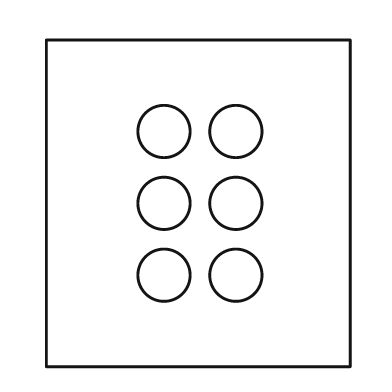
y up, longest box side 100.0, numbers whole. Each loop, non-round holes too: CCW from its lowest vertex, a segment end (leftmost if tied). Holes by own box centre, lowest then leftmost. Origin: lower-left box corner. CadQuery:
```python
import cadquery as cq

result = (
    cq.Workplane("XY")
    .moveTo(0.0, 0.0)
    .lineTo(93.0, 0.0)
    .lineTo(93.0, 100.0)
    .lineTo(0.0, 100.0)
    .close()
    .moveTo(36.0, 28.0)
    .circle(8.0)
    .moveTo(58.0, 28.0)
    .circle(8.0)
    .moveTo(36.0, 50.0)
    .circle(8.0)
    .moveTo(58.0, 50.0)
    .circle(8.0)
    .moveTo(36.0, 72.0)
    .circle(8.0)
    .moveTo(58.0, 72.0)
    .circle(8.0)
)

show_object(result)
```